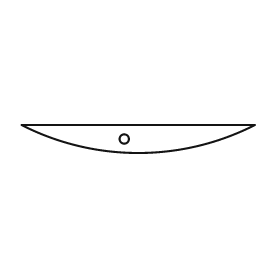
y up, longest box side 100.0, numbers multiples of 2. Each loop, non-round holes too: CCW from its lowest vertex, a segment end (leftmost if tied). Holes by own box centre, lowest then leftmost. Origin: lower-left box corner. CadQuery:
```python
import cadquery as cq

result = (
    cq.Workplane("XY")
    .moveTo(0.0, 12.0)
    .threePointArc((50.0, 0.0), (100.0, 12.0))
    .close()
    .moveTo(44.0, 6.0)
    .circle(2.0)
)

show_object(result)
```